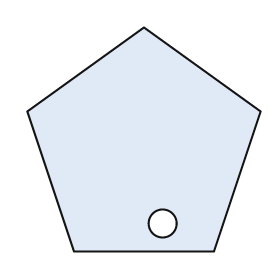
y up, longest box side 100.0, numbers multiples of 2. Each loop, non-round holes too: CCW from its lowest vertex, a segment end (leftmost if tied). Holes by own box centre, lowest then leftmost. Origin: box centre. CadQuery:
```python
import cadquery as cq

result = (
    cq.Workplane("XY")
    .moveTo(-30.0, -48.0)
    .lineTo(30.0, -48.0)
    .lineTo(50.0, 12.0)
    .lineTo(0.0, 48.0)
    .lineTo(-50.0, 12.0)
    .close()
    .moveTo(8.0, -36.0)
    .circle(6.0)
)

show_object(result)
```